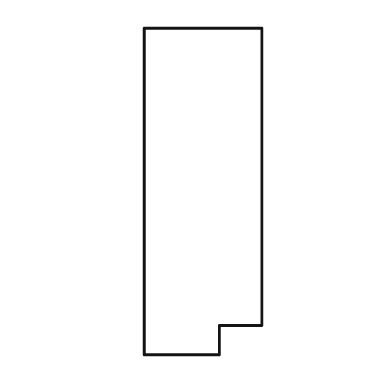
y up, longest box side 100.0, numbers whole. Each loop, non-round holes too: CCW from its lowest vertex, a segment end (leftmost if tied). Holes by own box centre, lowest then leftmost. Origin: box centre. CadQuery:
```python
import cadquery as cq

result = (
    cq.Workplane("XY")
    .moveTo(-18.0, -50.0)
    .lineTo(5.0, -50.0)
    .lineTo(5.0, -41.0)
    .lineTo(18.0, -41.0)
    .lineTo(18.0, 50.0)
    .lineTo(-18.0, 50.0)
    .close()
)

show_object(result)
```